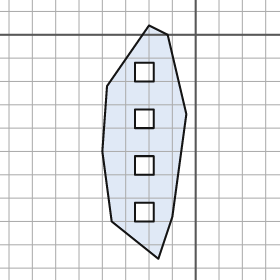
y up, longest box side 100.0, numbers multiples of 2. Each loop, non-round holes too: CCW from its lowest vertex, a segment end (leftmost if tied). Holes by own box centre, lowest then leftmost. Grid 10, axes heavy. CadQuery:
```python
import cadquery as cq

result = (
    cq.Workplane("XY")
    .moveTo(-16.0, -96.0)
    .lineTo(-10.0, -78.0)
    .lineTo(-4.0, -34.0)
    .lineTo(-12.0, 0.0)
    .lineTo(-20.0, 4.0)
    .lineTo(-38.0, -22.0)
    .lineTo(-40.0, -50.0)
    .lineTo(-36.0, -80.0)
    .close()
    .moveTo(-26.0, -80.0)
    .lineTo(-18.0, -80.0)
    .lineTo(-18.0, -72.0)
    .lineTo(-26.0, -72.0)
    .close()
    .moveTo(-26.0, -60.0)
    .lineTo(-18.0, -60.0)
    .lineTo(-18.0, -52.0)
    .lineTo(-26.0, -52.0)
    .close()
    .moveTo(-26.0, -40.0)
    .lineTo(-18.0, -40.0)
    .lineTo(-18.0, -32.0)
    .lineTo(-26.0, -32.0)
    .close()
    .moveTo(-26.0, -20.0)
    .lineTo(-18.0, -20.0)
    .lineTo(-18.0, -12.0)
    .lineTo(-26.0, -12.0)
    .close()
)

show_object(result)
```